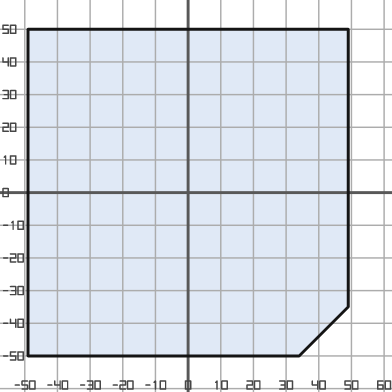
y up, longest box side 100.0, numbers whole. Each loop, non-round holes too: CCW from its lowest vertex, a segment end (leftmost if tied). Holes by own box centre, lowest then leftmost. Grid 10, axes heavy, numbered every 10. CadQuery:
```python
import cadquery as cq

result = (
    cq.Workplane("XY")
    .moveTo(-49.0, -50.0)
    .lineTo(34.0, -50.0)
    .lineTo(49.0, -35.0)
    .lineTo(49.0, 50.0)
    .lineTo(-49.0, 50.0)
    .close()
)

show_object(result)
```